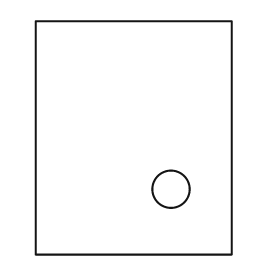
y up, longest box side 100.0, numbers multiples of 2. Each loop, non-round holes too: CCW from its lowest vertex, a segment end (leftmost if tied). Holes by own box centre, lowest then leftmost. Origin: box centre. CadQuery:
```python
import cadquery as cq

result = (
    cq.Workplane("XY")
    .moveTo(-42.0, -50.0)
    .lineTo(42.0, -50.0)
    .lineTo(42.0, 50.0)
    .lineTo(-42.0, 50.0)
    .close()
    .moveTo(16.0, -22.0)
    .circle(8.0)
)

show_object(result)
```